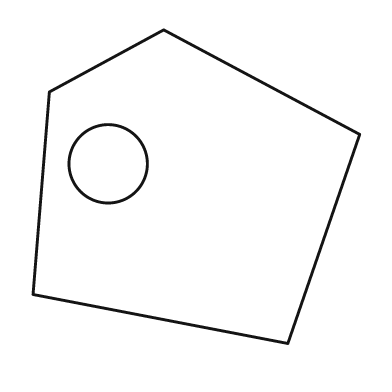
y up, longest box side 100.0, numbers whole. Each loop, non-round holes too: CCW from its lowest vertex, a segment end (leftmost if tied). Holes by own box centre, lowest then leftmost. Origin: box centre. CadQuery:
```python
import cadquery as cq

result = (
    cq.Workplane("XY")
    .moveTo(28.0, -48.0)
    .lineTo(50.0, 16.0)
    .lineTo(-10.0, 48.0)
    .lineTo(-45.0, 29.0)
    .lineTo(-50.0, -33.0)
    .close()
    .moveTo(-27.0, 7.0)
    .circle(12.0)
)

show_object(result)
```